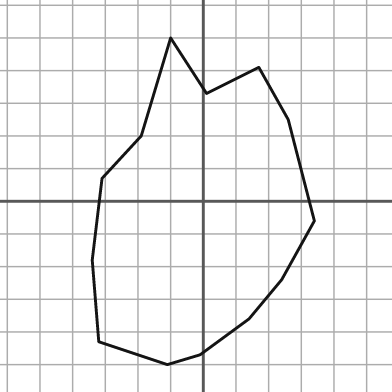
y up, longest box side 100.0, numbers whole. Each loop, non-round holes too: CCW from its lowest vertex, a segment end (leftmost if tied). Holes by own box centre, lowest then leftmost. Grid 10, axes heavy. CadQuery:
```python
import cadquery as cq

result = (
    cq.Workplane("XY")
    .moveTo(-11.0, -50.0)
    .lineTo(-1.0, -47.0)
    .lineTo(14.0, -36.0)
    .lineTo(24.0, -24.0)
    .lineTo(34.0, -6.0)
    .lineTo(26.0, 25.0)
    .lineTo(17.0, 41.0)
    .lineTo(1.0, 33.0)
    .lineTo(-10.0, 50.0)
    .lineTo(-19.0, 20.0)
    .lineTo(-31.0, 7.0)
    .lineTo(-34.0, -18.0)
    .lineTo(-32.0, -43.0)
    .close()
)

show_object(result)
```